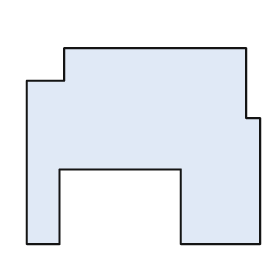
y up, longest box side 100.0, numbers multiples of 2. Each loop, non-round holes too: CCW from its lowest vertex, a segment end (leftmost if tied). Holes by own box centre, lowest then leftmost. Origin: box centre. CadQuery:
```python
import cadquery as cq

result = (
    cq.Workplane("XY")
    .moveTo(-50.0, -42.0)
    .lineTo(-36.0, -42.0)
    .lineTo(-36.0, -10.0)
    .lineTo(16.0, -10.0)
    .lineTo(16.0, -42.0)
    .lineTo(50.0, -42.0)
    .lineTo(50.0, 12.0)
    .lineTo(44.0, 12.0)
    .lineTo(44.0, 42.0)
    .lineTo(-34.0, 42.0)
    .lineTo(-34.0, 28.0)
    .lineTo(-50.0, 28.0)
    .close()
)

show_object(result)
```